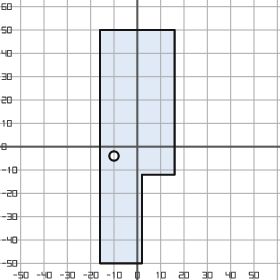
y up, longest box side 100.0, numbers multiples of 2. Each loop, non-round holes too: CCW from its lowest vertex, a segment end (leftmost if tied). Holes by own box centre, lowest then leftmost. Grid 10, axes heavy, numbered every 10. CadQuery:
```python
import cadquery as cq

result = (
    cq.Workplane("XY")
    .moveTo(-16.0, -50.0)
    .lineTo(2.0, -50.0)
    .lineTo(2.0, -12.0)
    .lineTo(16.0, -12.0)
    .lineTo(16.0, 50.0)
    .lineTo(-16.0, 50.0)
    .close()
    .moveTo(-10.0, -4.0)
    .circle(2.0)
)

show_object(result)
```